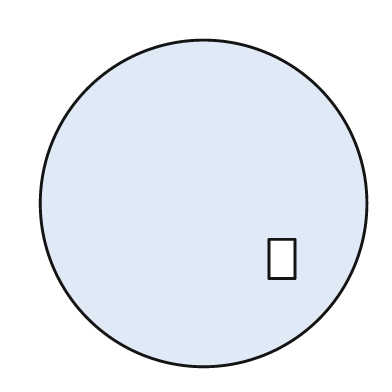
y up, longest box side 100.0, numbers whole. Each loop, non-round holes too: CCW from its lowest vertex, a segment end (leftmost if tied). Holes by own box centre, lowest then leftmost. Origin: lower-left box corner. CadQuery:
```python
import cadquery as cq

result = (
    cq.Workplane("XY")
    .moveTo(50.0, 50.0)
    .circle(50.0)
    .moveTo(70.0, 27.0)
    .lineTo(78.0, 27.0)
    .lineTo(78.0, 39.0)
    .lineTo(70.0, 39.0)
    .close()
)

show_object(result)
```